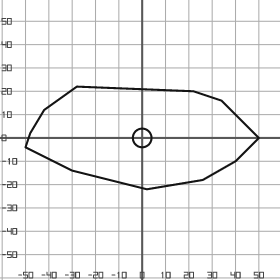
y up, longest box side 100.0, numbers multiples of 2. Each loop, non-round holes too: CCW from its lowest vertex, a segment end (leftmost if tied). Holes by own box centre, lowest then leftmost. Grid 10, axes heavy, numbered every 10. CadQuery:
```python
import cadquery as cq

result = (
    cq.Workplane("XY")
    .moveTo(2.0, -22.0)
    .lineTo(26.0, -18.0)
    .lineTo(40.0, -10.0)
    .lineTo(50.0, 0.0)
    .lineTo(34.0, 16.0)
    .lineTo(22.0, 20.0)
    .lineTo(-28.0, 22.0)
    .lineTo(-42.0, 12.0)
    .lineTo(-48.0, 2.0)
    .lineTo(-50.0, -4.0)
    .lineTo(-30.0, -14.0)
    .close()
    .moveTo(0.0, 0.0)
    .circle(4.0)
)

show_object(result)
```